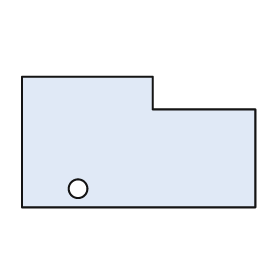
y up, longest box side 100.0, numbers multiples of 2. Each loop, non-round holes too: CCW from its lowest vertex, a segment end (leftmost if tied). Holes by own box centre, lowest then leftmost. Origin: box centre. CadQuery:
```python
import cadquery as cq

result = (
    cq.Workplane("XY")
    .moveTo(-50.0, -28.0)
    .lineTo(50.0, -28.0)
    .lineTo(50.0, 14.0)
    .lineTo(6.0, 14.0)
    .lineTo(6.0, 28.0)
    .lineTo(-50.0, 28.0)
    .close()
    .moveTo(-26.0, -20.0)
    .circle(4.0)
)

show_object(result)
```